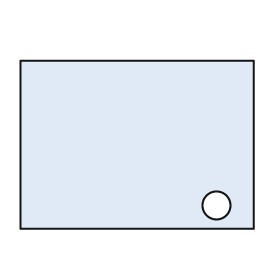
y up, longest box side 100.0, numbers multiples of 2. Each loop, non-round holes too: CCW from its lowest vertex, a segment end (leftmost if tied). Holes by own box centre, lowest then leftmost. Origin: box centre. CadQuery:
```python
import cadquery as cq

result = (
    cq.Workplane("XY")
    .moveTo(-50.0, -36.0)
    .lineTo(50.0, -36.0)
    .lineTo(50.0, 36.0)
    .lineTo(-50.0, 36.0)
    .close()
    .moveTo(34.0, -26.0)
    .circle(6.0)
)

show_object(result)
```